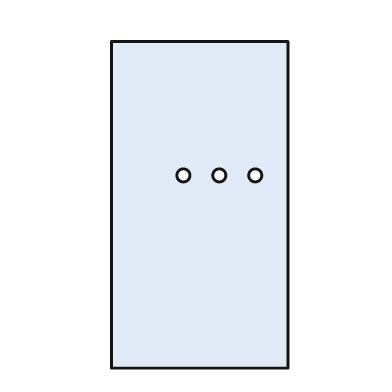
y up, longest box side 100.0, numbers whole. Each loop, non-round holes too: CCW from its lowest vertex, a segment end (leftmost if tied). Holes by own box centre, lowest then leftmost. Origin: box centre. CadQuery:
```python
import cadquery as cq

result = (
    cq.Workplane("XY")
    .moveTo(-27.0, -50.0)
    .lineTo(27.0, -50.0)
    .lineTo(27.0, 50.0)
    .lineTo(-27.0, 50.0)
    .close()
    .moveTo(-5.0, 9.0)
    .circle(2.0)
    .moveTo(6.0, 9.0)
    .circle(2.0)
    .moveTo(17.0, 9.0)
    .circle(2.0)
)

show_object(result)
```